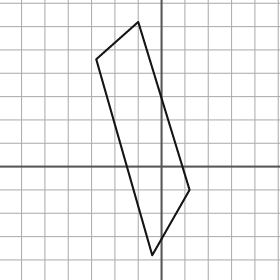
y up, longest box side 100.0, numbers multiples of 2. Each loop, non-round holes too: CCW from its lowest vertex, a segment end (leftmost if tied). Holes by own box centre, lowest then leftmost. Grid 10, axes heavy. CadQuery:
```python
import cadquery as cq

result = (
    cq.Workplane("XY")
    .moveTo(-4.0, -38.0)
    .lineTo(12.0, -10.0)
    .lineTo(-10.0, 62.0)
    .lineTo(-28.0, 46.0)
    .close()
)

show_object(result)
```